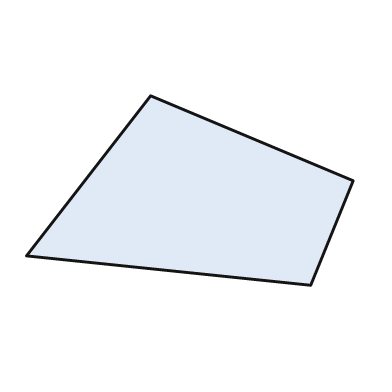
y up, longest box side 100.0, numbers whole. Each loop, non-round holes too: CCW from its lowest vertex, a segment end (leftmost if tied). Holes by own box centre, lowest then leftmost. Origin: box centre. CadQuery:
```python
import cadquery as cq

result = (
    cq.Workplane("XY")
    .moveTo(37.0, -29.0)
    .lineTo(50.0, 3.0)
    .lineTo(-12.0, 29.0)
    .lineTo(-50.0, -20.0)
    .close()
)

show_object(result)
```